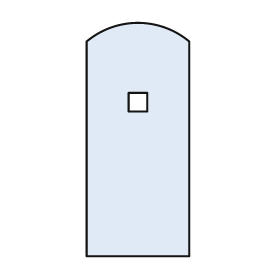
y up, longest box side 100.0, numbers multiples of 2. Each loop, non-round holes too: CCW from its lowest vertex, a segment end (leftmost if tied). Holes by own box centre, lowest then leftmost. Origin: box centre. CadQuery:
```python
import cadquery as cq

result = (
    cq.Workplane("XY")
    .moveTo(-22.0, -50.0)
    .lineTo(22.0, -50.0)
    .lineTo(22.0, 42.0)
    .threePointArc((0.0, 50.0), (-22.0, 42.0))
    .close()
    .moveTo(-4.0, 12.0)
    .lineTo(4.0, 12.0)
    .lineTo(4.0, 20.0)
    .lineTo(-4.0, 20.0)
    .close()
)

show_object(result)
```